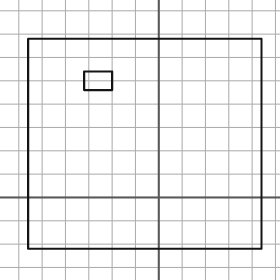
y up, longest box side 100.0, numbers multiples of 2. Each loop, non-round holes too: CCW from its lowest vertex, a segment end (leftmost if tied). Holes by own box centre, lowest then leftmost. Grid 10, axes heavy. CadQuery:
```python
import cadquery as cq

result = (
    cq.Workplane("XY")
    .moveTo(-56.0, -22.0)
    .lineTo(44.0, -22.0)
    .lineTo(44.0, 68.0)
    .lineTo(-56.0, 68.0)
    .close()
    .moveTo(-32.0, 46.0)
    .lineTo(-20.0, 46.0)
    .lineTo(-20.0, 54.0)
    .lineTo(-32.0, 54.0)
    .close()
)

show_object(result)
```